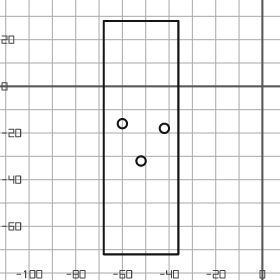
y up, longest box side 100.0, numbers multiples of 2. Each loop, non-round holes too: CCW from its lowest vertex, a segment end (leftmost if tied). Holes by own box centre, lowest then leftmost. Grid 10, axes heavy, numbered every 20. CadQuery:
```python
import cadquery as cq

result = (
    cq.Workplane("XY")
    .moveTo(-68.0, -72.0)
    .lineTo(-36.0, -72.0)
    .lineTo(-36.0, 28.0)
    .lineTo(-68.0, 28.0)
    .close()
    .moveTo(-52.0, -32.0)
    .circle(2.0)
    .moveTo(-42.0, -18.0)
    .circle(2.0)
    .moveTo(-60.0, -16.0)
    .circle(2.0)
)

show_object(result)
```